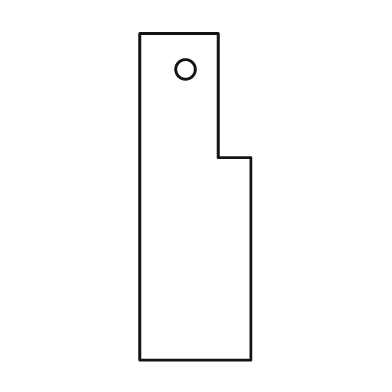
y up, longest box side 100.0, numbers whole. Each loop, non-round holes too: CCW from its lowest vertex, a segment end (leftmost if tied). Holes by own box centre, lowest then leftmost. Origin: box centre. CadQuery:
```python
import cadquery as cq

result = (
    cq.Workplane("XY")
    .moveTo(-17.0, -50.0)
    .lineTo(17.0, -50.0)
    .lineTo(17.0, 12.0)
    .lineTo(7.0, 12.0)
    .lineTo(7.0, 50.0)
    .lineTo(-17.0, 50.0)
    .close()
    .moveTo(-3.0, 39.0)
    .circle(3.0)
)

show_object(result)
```